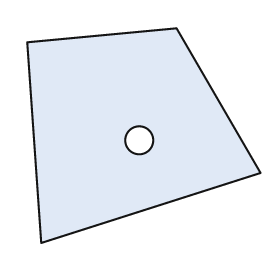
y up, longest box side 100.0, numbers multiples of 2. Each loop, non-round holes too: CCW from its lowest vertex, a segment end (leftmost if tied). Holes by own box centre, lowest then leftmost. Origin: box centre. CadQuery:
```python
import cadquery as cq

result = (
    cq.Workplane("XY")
    .moveTo(-44.0, -46.0)
    .lineTo(50.0, -16.0)
    .lineTo(14.0, 46.0)
    .lineTo(-50.0, 40.0)
    .close()
    .moveTo(-2.0, -2.0)
    .circle(6.0)
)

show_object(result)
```